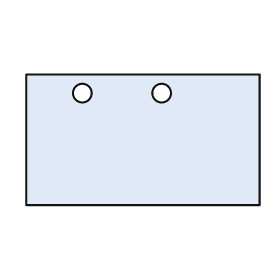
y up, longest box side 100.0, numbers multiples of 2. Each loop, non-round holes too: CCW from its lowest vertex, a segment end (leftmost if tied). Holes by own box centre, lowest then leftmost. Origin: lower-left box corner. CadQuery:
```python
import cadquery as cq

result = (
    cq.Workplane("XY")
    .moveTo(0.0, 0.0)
    .lineTo(100.0, 0.0)
    .lineTo(100.0, 56.0)
    .lineTo(0.0, 56.0)
    .close()
    .moveTo(24.0, 48.0)
    .circle(4.0)
    .moveTo(58.0, 48.0)
    .circle(4.0)
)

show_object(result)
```